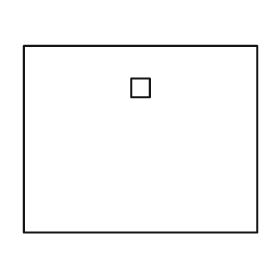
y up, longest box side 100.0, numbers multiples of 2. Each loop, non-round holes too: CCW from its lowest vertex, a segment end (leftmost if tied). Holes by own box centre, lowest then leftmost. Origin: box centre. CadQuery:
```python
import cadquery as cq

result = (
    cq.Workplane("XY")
    .moveTo(-50.0, -40.0)
    .lineTo(50.0, -40.0)
    .lineTo(50.0, 40.0)
    .lineTo(-50.0, 40.0)
    .close()
    .moveTo(-4.0, 18.0)
    .lineTo(4.0, 18.0)
    .lineTo(4.0, 26.0)
    .lineTo(-4.0, 26.0)
    .close()
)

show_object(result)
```